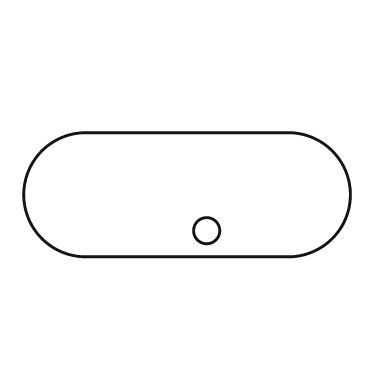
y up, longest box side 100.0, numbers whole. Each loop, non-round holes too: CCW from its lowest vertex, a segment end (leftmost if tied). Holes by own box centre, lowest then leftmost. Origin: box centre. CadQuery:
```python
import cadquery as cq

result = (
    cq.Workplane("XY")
    .moveTo(-31.0, -19.0)
    .lineTo(31.0, -19.0)
    .threePointArc((50.0, 0.0), (31.0, 19.0))
    .lineTo(-31.0, 19.0)
    .threePointArc((-50.0, 0.0), (-31.0, -19.0))
    .close()
    .moveTo(6.0, -11.0)
    .circle(4.0)
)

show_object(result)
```